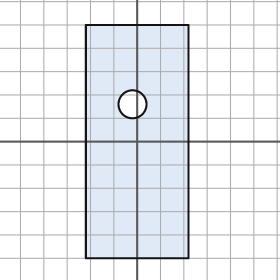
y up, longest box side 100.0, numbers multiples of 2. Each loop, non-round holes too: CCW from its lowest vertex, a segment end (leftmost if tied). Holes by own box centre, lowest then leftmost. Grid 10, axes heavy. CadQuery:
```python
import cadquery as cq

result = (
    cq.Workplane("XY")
    .moveTo(-22.0, -50.0)
    .lineTo(22.0, -50.0)
    .lineTo(22.0, 50.0)
    .lineTo(-22.0, 50.0)
    .close()
    .moveTo(-2.0, 16.0)
    .circle(6.0)
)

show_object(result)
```